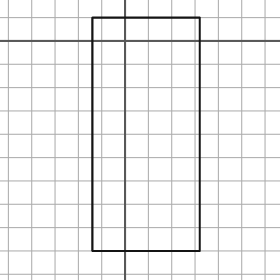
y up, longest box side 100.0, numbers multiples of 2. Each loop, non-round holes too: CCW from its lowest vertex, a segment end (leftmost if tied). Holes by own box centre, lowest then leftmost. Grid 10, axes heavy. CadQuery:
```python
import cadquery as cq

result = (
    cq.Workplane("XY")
    .moveTo(-14.0, -90.0)
    .lineTo(32.0, -90.0)
    .lineTo(32.0, 10.0)
    .lineTo(-14.0, 10.0)
    .close()
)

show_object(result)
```